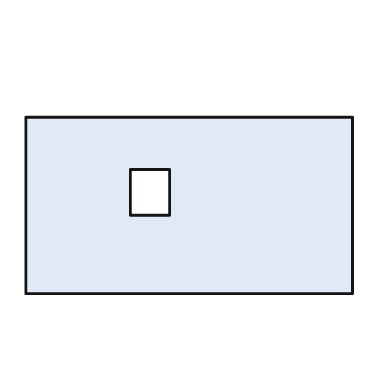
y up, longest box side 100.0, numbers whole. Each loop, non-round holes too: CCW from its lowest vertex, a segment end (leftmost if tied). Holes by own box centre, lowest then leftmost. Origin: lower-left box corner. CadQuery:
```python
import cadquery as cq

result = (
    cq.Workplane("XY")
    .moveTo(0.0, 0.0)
    .lineTo(100.0, 0.0)
    .lineTo(100.0, 54.0)
    .lineTo(0.0, 54.0)
    .close()
    .moveTo(32.0, 24.0)
    .lineTo(44.0, 24.0)
    .lineTo(44.0, 38.0)
    .lineTo(32.0, 38.0)
    .close()
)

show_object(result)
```